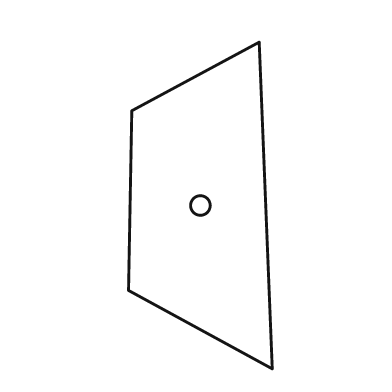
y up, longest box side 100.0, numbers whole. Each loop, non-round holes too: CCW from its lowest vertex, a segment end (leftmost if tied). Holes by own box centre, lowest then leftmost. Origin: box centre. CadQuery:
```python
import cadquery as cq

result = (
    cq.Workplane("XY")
    .moveTo(22.0, -50.0)
    .lineTo(18.0, 50.0)
    .lineTo(-21.0, 29.0)
    .lineTo(-22.0, -26.0)
    .close()
    .moveTo(0.0, 0.0)
    .circle(3.0)
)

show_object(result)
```